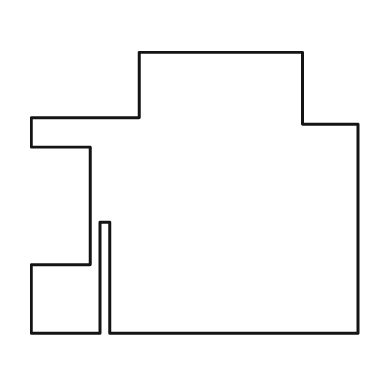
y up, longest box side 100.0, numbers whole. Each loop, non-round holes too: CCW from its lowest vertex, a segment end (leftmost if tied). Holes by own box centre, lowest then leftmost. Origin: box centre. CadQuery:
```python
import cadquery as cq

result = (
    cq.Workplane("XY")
    .moveTo(-50.0, -43.0)
    .lineTo(-29.0, -43.0)
    .lineTo(-29.0, -9.0)
    .lineTo(-26.0, -9.0)
    .lineTo(-26.0, -43.0)
    .lineTo(50.0, -43.0)
    .lineTo(50.0, 21.0)
    .lineTo(33.0, 21.0)
    .lineTo(33.0, 43.0)
    .lineTo(-17.0, 43.0)
    .lineTo(-17.0, 23.0)
    .lineTo(-50.0, 23.0)
    .lineTo(-50.0, 14.0)
    .lineTo(-32.0, 14.0)
    .lineTo(-32.0, -22.0)
    .lineTo(-50.0, -22.0)
    .close()
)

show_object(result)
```